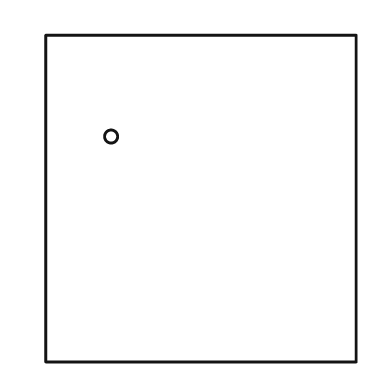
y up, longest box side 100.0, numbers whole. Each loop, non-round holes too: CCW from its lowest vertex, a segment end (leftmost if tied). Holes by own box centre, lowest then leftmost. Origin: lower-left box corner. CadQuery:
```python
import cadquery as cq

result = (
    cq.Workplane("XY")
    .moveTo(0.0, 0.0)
    .lineTo(95.0, 0.0)
    .lineTo(95.0, 100.0)
    .lineTo(0.0, 100.0)
    .close()
    .moveTo(20.0, 69.0)
    .circle(2.0)
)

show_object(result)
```